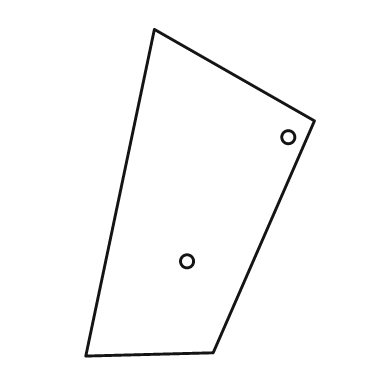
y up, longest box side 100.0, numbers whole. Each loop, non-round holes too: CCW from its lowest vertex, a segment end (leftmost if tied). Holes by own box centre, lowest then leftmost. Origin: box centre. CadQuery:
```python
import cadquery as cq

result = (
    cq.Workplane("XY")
    .moveTo(-35.0, -50.0)
    .lineTo(4.0, -49.0)
    .lineTo(35.0, 22.0)
    .lineTo(-14.0, 50.0)
    .close()
    .moveTo(-4.0, -21.0)
    .circle(2.0)
    .moveTo(27.0, 17.0)
    .circle(2.0)
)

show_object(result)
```